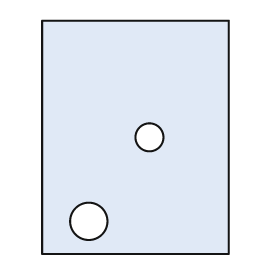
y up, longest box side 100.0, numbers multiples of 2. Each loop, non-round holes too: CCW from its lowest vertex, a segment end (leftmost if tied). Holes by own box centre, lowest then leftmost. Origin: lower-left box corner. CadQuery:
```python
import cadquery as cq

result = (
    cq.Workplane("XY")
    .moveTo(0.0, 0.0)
    .lineTo(80.0, 0.0)
    .lineTo(80.0, 100.0)
    .lineTo(0.0, 100.0)
    .close()
    .moveTo(20.0, 14.0)
    .circle(8.0)
    .moveTo(46.0, 50.0)
    .circle(6.0)
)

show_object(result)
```